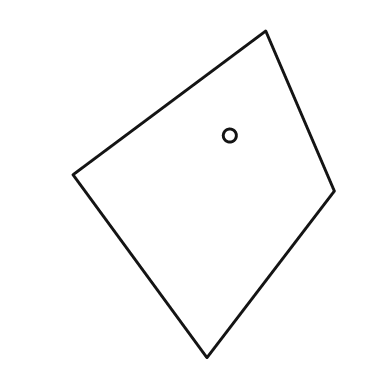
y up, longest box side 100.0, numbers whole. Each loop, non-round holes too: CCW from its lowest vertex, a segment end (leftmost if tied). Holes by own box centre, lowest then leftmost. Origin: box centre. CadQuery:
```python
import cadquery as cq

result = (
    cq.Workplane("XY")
    .moveTo(1.0, -50.0)
    .lineTo(40.0, 1.0)
    .lineTo(19.0, 50.0)
    .lineTo(-40.0, 6.0)
    .close()
    .moveTo(8.0, 18.0)
    .circle(2.0)
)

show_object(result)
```